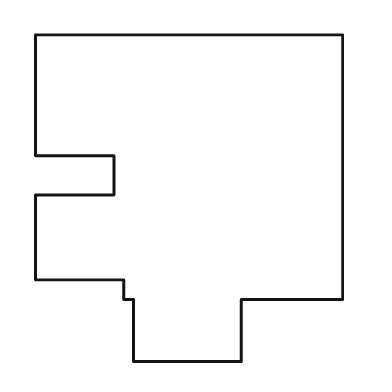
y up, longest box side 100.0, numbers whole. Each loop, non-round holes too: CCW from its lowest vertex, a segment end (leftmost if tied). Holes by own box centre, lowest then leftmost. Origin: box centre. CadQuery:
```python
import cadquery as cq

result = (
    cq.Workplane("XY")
    .moveTo(-17.0, -50.0)
    .lineTo(16.0, -50.0)
    .lineTo(16.0, -31.0)
    .lineTo(47.0, -31.0)
    .lineTo(47.0, 50.0)
    .lineTo(-47.0, 50.0)
    .lineTo(-47.0, 13.0)
    .lineTo(-23.0, 13.0)
    .lineTo(-23.0, 1.0)
    .lineTo(-47.0, 1.0)
    .lineTo(-47.0, -25.0)
    .lineTo(-20.0, -25.0)
    .lineTo(-20.0, -31.0)
    .lineTo(-17.0, -31.0)
    .close()
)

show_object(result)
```